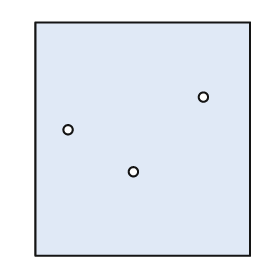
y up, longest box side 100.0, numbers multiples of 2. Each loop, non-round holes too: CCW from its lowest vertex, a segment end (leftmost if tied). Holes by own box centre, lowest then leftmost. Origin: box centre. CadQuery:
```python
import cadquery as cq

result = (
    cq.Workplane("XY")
    .moveTo(-46.0, -50.0)
    .lineTo(46.0, -50.0)
    .lineTo(46.0, 50.0)
    .lineTo(-46.0, 50.0)
    .close()
    .moveTo(-4.0, -14.0)
    .circle(2.0)
    .moveTo(-32.0, 4.0)
    .circle(2.0)
    .moveTo(26.0, 18.0)
    .circle(2.0)
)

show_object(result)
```